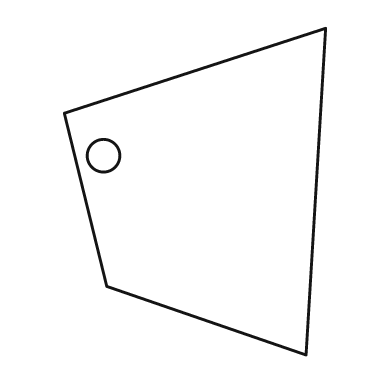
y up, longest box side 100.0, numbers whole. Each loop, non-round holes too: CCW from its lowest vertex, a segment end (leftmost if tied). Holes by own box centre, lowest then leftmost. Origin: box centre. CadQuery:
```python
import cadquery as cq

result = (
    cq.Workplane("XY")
    .moveTo(34.0, -50.0)
    .lineTo(40.0, 50.0)
    .lineTo(-40.0, 24.0)
    .lineTo(-27.0, -29.0)
    .close()
    .moveTo(-28.0, 11.0)
    .circle(5.0)
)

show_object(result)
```